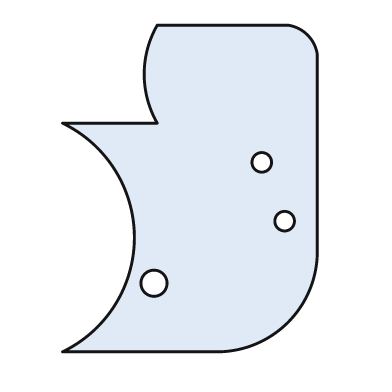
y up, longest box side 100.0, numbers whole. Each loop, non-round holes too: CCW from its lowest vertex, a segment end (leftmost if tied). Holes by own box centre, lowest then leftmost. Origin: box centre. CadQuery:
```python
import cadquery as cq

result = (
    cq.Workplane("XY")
    .moveTo(-39.0, -50.0)
    .lineTo(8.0, -50.0)
    .threePointArc((30.0, -41.0), (39.0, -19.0))
    .lineTo(39.0, 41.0)
    .threePointArc((36.0, 47.0), (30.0, 50.0))
    .lineTo(-10.0, 50.0)
    .threePointArc((-14.0, 35.0), (-10.0, 20.0))
    .lineTo(-39.0, 20.0)
    .threePointArc((-17.0, -15.0), (-39.0, -50.0))
    .close()
    .moveTo(-11.0, -29.0)
    .circle(4.0)
    .moveTo(29.0, -10.0)
    .circle(3.0)
    .moveTo(22.0, 8.0)
    .circle(3.0)
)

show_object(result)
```